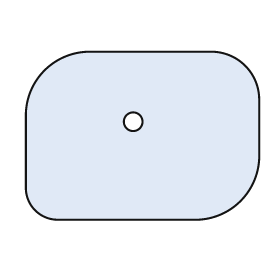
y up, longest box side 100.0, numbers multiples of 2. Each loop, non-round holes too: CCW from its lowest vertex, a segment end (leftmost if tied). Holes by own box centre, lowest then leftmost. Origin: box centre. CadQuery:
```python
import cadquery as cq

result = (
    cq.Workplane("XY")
    .moveTo(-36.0, -36.0)
    .lineTo(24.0, -36.0)
    .threePointArc((42.0, -28.0), (50.0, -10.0))
    .lineTo(50.0, 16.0)
    .threePointArc((44.0, 30.0), (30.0, 36.0))
    .lineTo(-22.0, 36.0)
    .threePointArc((-42.0, 28.0), (-50.0, 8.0))
    .lineTo(-50.0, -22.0)
    .threePointArc((-46.0, -32.0), (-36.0, -36.0))
    .close()
    .moveTo(-4.0, 6.0)
    .circle(4.0)
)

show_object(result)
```